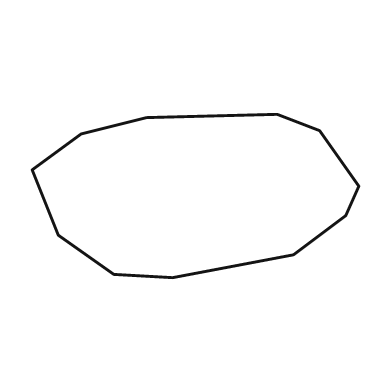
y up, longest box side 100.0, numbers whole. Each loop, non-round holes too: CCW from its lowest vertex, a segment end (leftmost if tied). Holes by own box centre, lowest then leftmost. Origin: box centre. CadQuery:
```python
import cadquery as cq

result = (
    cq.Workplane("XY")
    .moveTo(-7.0, -25.0)
    .lineTo(30.0, -18.0)
    .lineTo(46.0, -6.0)
    .lineTo(50.0, 3.0)
    .lineTo(38.0, 20.0)
    .lineTo(25.0, 25.0)
    .lineTo(-15.0, 24.0)
    .lineTo(-35.0, 19.0)
    .lineTo(-50.0, 8.0)
    .lineTo(-42.0, -12.0)
    .lineTo(-25.0, -24.0)
    .close()
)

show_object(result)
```